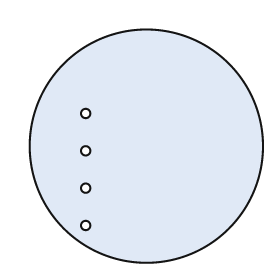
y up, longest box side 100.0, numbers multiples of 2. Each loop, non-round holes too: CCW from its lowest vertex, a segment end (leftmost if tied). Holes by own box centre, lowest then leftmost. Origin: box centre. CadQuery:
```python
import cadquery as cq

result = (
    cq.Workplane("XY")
    .moveTo(0.0, 0.0)
    .circle(50.0)
    .moveTo(-26.0, -34.0)
    .circle(2.0)
    .moveTo(-26.0, -18.0)
    .circle(2.0)
    .moveTo(-26.0, -2.0)
    .circle(2.0)
    .moveTo(-26.0, 14.0)
    .circle(2.0)
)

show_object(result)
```